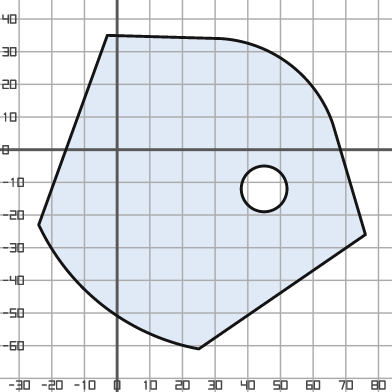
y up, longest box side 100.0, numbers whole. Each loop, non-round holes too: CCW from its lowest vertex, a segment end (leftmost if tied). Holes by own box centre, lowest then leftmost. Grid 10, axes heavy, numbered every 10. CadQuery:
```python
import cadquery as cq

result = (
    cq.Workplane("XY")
    .moveTo(25.0, -61.0)
    .lineTo(76.0, -26.0)
    .lineTo(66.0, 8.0)
    .threePointArc((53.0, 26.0), (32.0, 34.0))
    .lineTo(-3.0, 35.0)
    .lineTo(-24.0, -23.0)
    .threePointArc((-4.0, -48.0), (25.0, -61.0))
    .close()
    .moveTo(45.0, -12.0)
    .circle(7.0)
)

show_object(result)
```